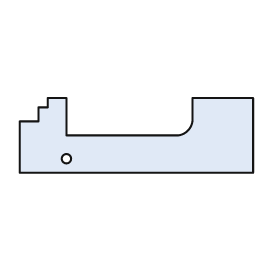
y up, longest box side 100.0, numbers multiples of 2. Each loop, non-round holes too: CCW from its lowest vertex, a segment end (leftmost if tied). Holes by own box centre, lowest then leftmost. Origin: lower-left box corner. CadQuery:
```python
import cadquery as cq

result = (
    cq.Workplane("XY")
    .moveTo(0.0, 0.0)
    .lineTo(100.0, 0.0)
    .lineTo(100.0, 32.0)
    .lineTo(74.0, 32.0)
    .lineTo(74.0, 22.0)
    .threePointArc((72.0, 18.0), (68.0, 16.0))
    .lineTo(20.0, 16.0)
    .lineTo(20.0, 32.0)
    .lineTo(12.0, 32.0)
    .lineTo(12.0, 28.0)
    .lineTo(8.0, 28.0)
    .lineTo(8.0, 22.0)
    .lineTo(0.0, 22.0)
    .close()
    .moveTo(20.0, 6.0)
    .circle(2.0)
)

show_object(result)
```